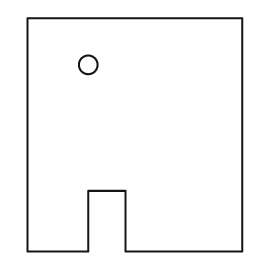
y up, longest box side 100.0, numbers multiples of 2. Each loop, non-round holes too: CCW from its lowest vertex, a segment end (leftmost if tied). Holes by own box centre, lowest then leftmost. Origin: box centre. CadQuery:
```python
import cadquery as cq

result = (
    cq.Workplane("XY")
    .moveTo(-46.0, -50.0)
    .lineTo(-20.0, -50.0)
    .lineTo(-20.0, -24.0)
    .lineTo(-4.0, -24.0)
    .lineTo(-4.0, -50.0)
    .lineTo(46.0, -50.0)
    .lineTo(46.0, 50.0)
    .lineTo(-46.0, 50.0)
    .close()
    .moveTo(-20.0, 30.0)
    .circle(4.0)
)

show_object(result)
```